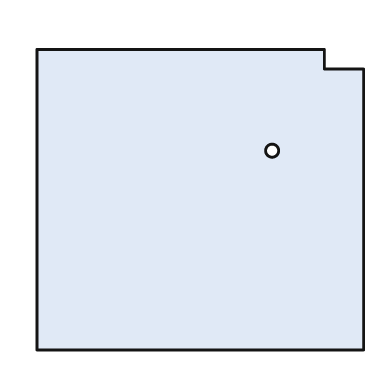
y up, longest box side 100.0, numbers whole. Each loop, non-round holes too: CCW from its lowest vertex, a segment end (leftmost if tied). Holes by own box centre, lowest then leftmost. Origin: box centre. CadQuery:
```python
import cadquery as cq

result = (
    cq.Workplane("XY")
    .moveTo(-50.0, -46.0)
    .lineTo(50.0, -46.0)
    .lineTo(50.0, 40.0)
    .lineTo(38.0, 40.0)
    .lineTo(38.0, 46.0)
    .lineTo(-50.0, 46.0)
    .close()
    .moveTo(22.0, 15.0)
    .circle(2.0)
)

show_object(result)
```